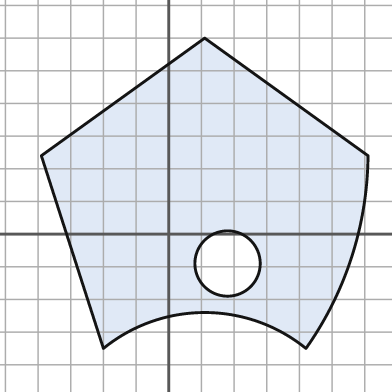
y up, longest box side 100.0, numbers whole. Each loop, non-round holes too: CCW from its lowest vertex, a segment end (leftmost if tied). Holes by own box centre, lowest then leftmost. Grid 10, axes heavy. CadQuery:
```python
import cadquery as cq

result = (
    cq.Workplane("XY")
    .moveTo(-20.0, -35.0)
    .threePointArc((11.0, -24.0), (42.0, -35.0))
    .threePointArc((56.0, -7.0), (61.0, 24.0))
    .lineTo(11.0, 60.0)
    .lineTo(-39.0, 24.0)
    .close()
    .moveTo(18.0, -9.0)
    .circle(10.0)
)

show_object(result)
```